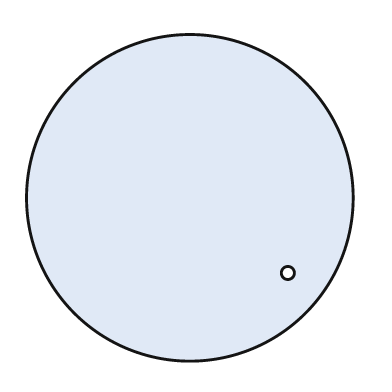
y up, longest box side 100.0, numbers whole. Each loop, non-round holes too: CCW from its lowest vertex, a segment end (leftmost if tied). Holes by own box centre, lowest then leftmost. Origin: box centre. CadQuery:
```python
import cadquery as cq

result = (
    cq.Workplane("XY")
    .moveTo(0.0, 0.0)
    .circle(50.0)
    .moveTo(30.0, -23.0)
    .circle(2.0)
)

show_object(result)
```